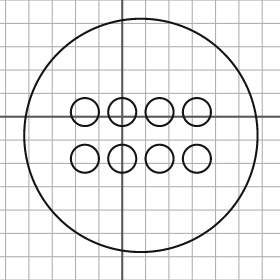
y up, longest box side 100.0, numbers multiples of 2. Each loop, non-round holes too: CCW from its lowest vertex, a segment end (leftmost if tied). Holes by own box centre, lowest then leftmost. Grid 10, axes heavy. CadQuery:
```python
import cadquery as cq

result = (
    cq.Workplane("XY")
    .moveTo(8.0, -8.0)
    .circle(50.0)
    .moveTo(-16.0, -18.0)
    .circle(6.0)
    .moveTo(0.0, -18.0)
    .circle(6.0)
    .moveTo(16.0, -18.0)
    .circle(6.0)
    .moveTo(32.0, -18.0)
    .circle(6.0)
    .moveTo(-16.0, 2.0)
    .circle(6.0)
    .moveTo(0.0, 2.0)
    .circle(6.0)
    .moveTo(16.0, 2.0)
    .circle(6.0)
    .moveTo(32.0, 2.0)
    .circle(6.0)
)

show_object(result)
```